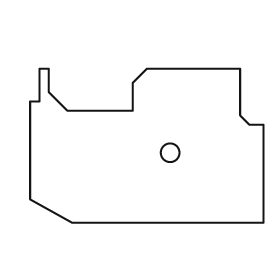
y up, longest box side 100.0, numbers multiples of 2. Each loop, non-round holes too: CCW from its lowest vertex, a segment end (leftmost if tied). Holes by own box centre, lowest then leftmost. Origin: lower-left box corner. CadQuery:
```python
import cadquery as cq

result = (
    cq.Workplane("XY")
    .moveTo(18.0, 0.0)
    .lineTo(100.0, 0.0)
    .lineTo(100.0, 42.0)
    .lineTo(94.0, 42.0)
    .lineTo(90.0, 46.0)
    .lineTo(90.0, 66.0)
    .lineTo(50.0, 66.0)
    .lineTo(44.0, 60.0)
    .lineTo(44.0, 48.0)
    .lineTo(16.0, 48.0)
    .lineTo(8.0, 56.0)
    .lineTo(8.0, 66.0)
    .lineTo(4.0, 66.0)
    .lineTo(4.0, 52.0)
    .lineTo(0.0, 52.0)
    .lineTo(0.0, 10.0)
    .close()
    .moveTo(60.0, 30.0)
    .circle(4.0)
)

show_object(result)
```